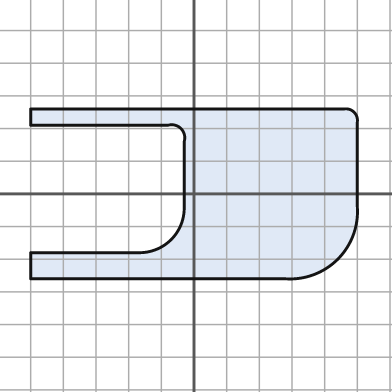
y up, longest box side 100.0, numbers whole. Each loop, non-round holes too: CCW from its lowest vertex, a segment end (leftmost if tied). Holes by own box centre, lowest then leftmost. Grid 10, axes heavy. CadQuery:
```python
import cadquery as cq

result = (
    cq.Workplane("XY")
    .moveTo(-50.0, -26.0)
    .lineTo(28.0, -26.0)
    .threePointArc((44.0, -20.0), (50.0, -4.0))
    .lineTo(50.0, 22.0)
    .threePointArc((49.0, 25.0), (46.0, 26.0))
    .lineTo(-50.0, 26.0)
    .lineTo(-50.0, 21.0)
    .lineTo(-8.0, 21.0)
    .threePointArc((-4.0, 20.0), (-3.0, 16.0))
    .lineTo(-3.0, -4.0)
    .threePointArc((-7.0, -14.0), (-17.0, -18.0))
    .lineTo(-50.0, -18.0)
    .close()
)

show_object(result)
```